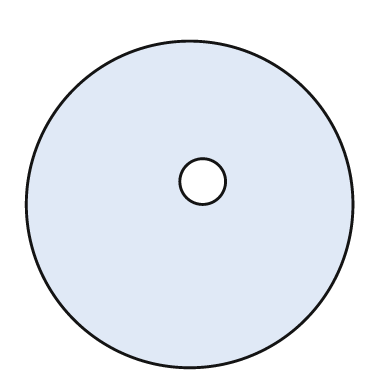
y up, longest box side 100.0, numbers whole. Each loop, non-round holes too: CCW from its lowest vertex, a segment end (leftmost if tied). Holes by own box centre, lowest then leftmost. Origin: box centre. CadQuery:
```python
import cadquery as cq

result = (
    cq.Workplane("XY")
    .moveTo(0.0, 0.0)
    .circle(50.0)
    .moveTo(4.0, 7.0)
    .circle(7.0)
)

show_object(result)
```